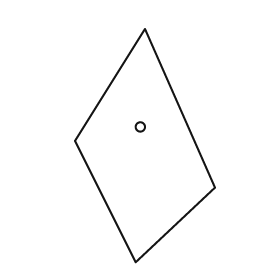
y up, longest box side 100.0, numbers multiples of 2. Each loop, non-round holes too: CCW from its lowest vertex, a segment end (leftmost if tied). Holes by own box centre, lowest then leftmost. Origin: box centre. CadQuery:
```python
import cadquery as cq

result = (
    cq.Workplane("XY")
    .moveTo(-4.0, -50.0)
    .lineTo(30.0, -18.0)
    .lineTo(0.0, 50.0)
    .lineTo(-30.0, 2.0)
    .close()
    .moveTo(-2.0, 8.0)
    .circle(2.0)
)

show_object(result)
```